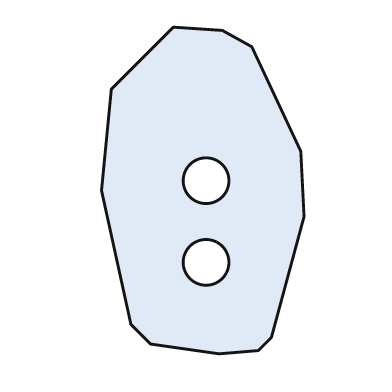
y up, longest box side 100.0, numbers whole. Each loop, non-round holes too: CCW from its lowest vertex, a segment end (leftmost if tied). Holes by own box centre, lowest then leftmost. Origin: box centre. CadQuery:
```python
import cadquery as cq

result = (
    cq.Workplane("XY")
    .moveTo(5.0, -50.0)
    .lineTo(17.0, -49.0)
    .lineTo(21.0, -45.0)
    .lineTo(31.0, -8.0)
    .lineTo(30.0, 12.0)
    .lineTo(15.0, 44.0)
    .lineTo(6.0, 49.0)
    .lineTo(-9.0, 50.0)
    .lineTo(-28.0, 31.0)
    .lineTo(-31.0, 0.0)
    .lineTo(-22.0, -41.0)
    .lineTo(-16.0, -47.0)
    .close()
    .moveTo(1.0, -22.0)
    .circle(7.0)
    .moveTo(1.0, 3.0)
    .circle(7.0)
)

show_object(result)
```